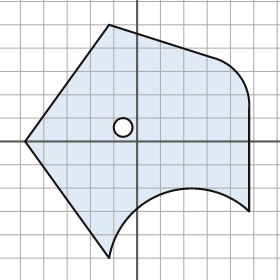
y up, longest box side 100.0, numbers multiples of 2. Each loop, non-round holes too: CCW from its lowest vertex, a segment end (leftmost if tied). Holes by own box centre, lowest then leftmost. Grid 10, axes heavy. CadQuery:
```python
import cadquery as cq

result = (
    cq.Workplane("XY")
    .moveTo(-12.0, -50.0)
    .threePointArc((12.0, -22.0), (48.0, -30.0))
    .lineTo(48.0, 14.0)
    .threePointArc((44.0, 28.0), (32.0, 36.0))
    .lineTo(-12.0, 50.0)
    .lineTo(-48.0, 0.0)
    .close()
    .moveTo(-6.0, 6.0)
    .circle(4.0)
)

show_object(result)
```